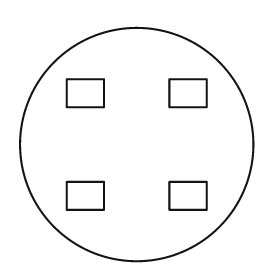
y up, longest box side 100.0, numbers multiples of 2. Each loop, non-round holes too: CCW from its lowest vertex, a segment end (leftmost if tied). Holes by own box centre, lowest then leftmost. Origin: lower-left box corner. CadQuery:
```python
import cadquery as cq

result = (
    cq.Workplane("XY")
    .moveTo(50.0, 50.0)
    .circle(50.0)
    .moveTo(20.0, 22.0)
    .lineTo(36.0, 22.0)
    .lineTo(36.0, 34.0)
    .lineTo(20.0, 34.0)
    .close()
    .moveTo(64.0, 22.0)
    .lineTo(80.0, 22.0)
    .lineTo(80.0, 34.0)
    .lineTo(64.0, 34.0)
    .close()
    .moveTo(20.0, 66.0)
    .lineTo(36.0, 66.0)
    .lineTo(36.0, 78.0)
    .lineTo(20.0, 78.0)
    .close()
    .moveTo(64.0, 66.0)
    .lineTo(80.0, 66.0)
    .lineTo(80.0, 78.0)
    .lineTo(64.0, 78.0)
    .close()
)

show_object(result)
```